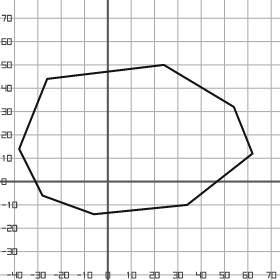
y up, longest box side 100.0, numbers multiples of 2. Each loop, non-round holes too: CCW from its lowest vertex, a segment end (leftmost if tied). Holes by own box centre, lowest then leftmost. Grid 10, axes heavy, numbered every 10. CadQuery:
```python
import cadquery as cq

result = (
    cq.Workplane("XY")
    .moveTo(-6.0, -14.0)
    .lineTo(34.0, -10.0)
    .lineTo(62.0, 12.0)
    .lineTo(54.0, 32.0)
    .lineTo(24.0, 50.0)
    .lineTo(-26.0, 44.0)
    .lineTo(-38.0, 14.0)
    .lineTo(-28.0, -6.0)
    .close()
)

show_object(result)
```